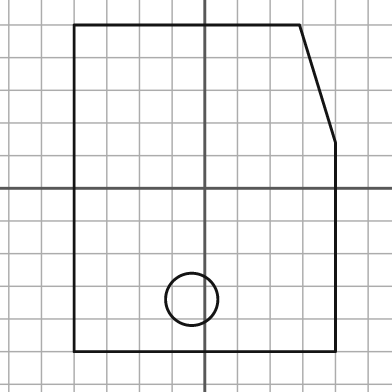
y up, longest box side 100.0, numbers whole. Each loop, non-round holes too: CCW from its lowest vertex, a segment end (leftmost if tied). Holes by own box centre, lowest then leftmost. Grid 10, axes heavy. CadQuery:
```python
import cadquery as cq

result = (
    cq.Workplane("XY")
    .moveTo(-40.0, -50.0)
    .lineTo(40.0, -50.0)
    .lineTo(40.0, 14.0)
    .lineTo(29.0, 50.0)
    .lineTo(-40.0, 50.0)
    .close()
    .moveTo(-4.0, -34.0)
    .circle(8.0)
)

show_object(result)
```